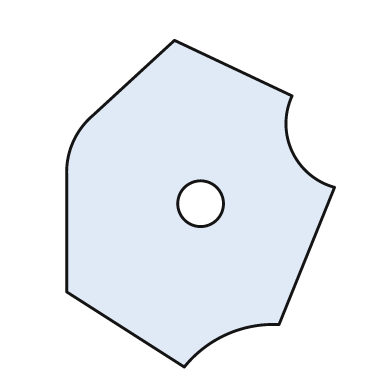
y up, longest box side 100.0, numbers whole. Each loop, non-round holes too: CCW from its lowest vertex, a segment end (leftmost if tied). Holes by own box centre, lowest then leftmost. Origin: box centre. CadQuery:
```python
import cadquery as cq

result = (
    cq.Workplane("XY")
    .moveTo(-5.0, -50.0)
    .threePointArc((8.0, -40.0), (24.0, -37.0))
    .lineTo(41.0, 5.0)
    .threePointArc((28.0, 16.0), (28.0, 33.0))
    .lineTo(-8.0, 50.0)
    .lineTo(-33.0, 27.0)
    .threePointArc((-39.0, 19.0), (-41.0, 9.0))
    .lineTo(-41.0, -27.0)
    .close()
    .moveTo(0.0, 0.0)
    .circle(7.0)
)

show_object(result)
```